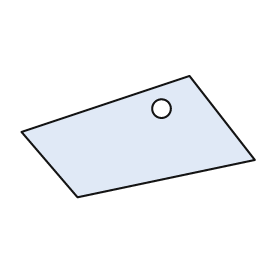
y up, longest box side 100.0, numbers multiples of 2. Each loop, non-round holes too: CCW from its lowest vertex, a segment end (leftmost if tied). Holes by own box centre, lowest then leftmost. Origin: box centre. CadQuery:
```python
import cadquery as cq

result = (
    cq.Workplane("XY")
    .moveTo(-26.0, -26.0)
    .lineTo(50.0, -10.0)
    .lineTo(22.0, 26.0)
    .lineTo(-50.0, 2.0)
    .close()
    .moveTo(10.0, 12.0)
    .circle(4.0)
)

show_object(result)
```